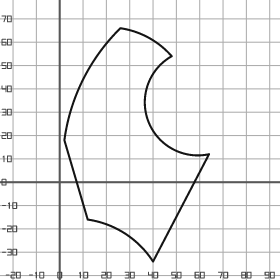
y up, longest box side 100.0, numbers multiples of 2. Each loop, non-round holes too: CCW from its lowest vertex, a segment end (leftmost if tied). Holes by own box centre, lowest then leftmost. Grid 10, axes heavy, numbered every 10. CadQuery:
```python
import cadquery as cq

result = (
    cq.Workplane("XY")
    .moveTo(40.0, -34.0)
    .lineTo(64.0, 12.0)
    .threePointArc((38.0, 26.0), (48.0, 54.0))
    .threePointArc((38.0, 62.0), (26.0, 66.0))
    .threePointArc((10.0, 44.0), (2.0, 18.0))
    .lineTo(12.0, -16.0)
    .threePointArc((28.0, -22.0), (40.0, -34.0))
    .close()
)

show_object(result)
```